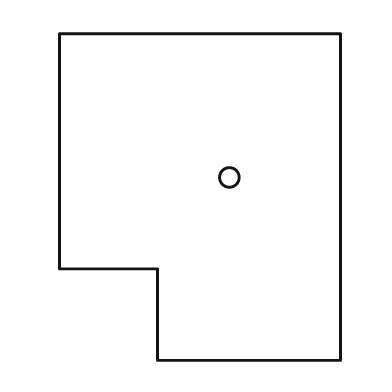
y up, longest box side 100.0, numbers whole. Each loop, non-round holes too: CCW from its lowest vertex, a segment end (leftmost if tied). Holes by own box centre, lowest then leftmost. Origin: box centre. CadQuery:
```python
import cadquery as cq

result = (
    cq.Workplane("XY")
    .moveTo(-13.0, -50.0)
    .lineTo(43.0, -50.0)
    .lineTo(43.0, 50.0)
    .lineTo(-43.0, 50.0)
    .lineTo(-43.0, -22.0)
    .lineTo(-13.0, -22.0)
    .close()
    .moveTo(9.0, 6.0)
    .circle(3.0)
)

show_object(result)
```